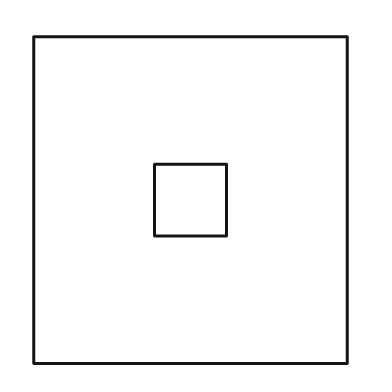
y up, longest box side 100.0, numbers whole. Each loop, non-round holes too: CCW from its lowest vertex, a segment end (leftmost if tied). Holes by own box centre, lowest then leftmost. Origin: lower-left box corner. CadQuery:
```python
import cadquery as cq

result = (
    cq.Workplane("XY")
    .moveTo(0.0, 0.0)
    .lineTo(96.0, 0.0)
    .lineTo(96.0, 100.0)
    .lineTo(0.0, 100.0)
    .close()
    .moveTo(37.0, 39.0)
    .lineTo(59.0, 39.0)
    .lineTo(59.0, 61.0)
    .lineTo(37.0, 61.0)
    .close()
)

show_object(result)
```